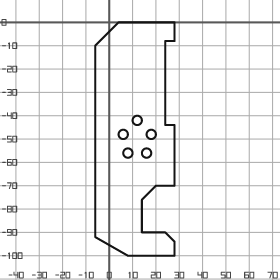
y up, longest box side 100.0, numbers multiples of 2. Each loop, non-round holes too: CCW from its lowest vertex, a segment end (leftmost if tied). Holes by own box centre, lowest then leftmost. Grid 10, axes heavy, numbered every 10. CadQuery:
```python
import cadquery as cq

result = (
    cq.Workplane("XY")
    .moveTo(8.0, -100.0)
    .lineTo(28.0, -100.0)
    .lineTo(28.0, -94.0)
    .lineTo(24.0, -90.0)
    .lineTo(14.0, -90.0)
    .lineTo(14.0, -76.0)
    .lineTo(20.0, -70.0)
    .lineTo(28.0, -70.0)
    .lineTo(28.0, -44.0)
    .lineTo(24.0, -44.0)
    .lineTo(24.0, -8.0)
    .lineTo(28.0, -8.0)
    .lineTo(28.0, 0.0)
    .lineTo(4.0, 0.0)
    .lineTo(-6.0, -10.0)
    .lineTo(-6.0, -92.0)
    .close()
    .moveTo(8.0, -56.0)
    .circle(2.0)
    .moveTo(16.0, -56.0)
    .circle(2.0)
    .moveTo(6.0, -48.0)
    .circle(2.0)
    .moveTo(18.0, -48.0)
    .circle(2.0)
    .moveTo(12.0, -42.0)
    .circle(2.0)
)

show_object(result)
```